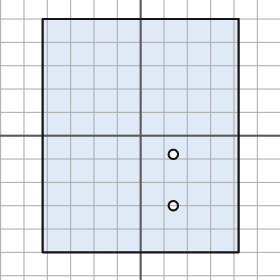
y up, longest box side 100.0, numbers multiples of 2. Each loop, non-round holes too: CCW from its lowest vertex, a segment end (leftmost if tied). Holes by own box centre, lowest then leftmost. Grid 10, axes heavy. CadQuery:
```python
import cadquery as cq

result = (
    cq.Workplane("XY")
    .moveTo(-42.0, -50.0)
    .lineTo(42.0, -50.0)
    .lineTo(42.0, 50.0)
    .lineTo(-42.0, 50.0)
    .close()
    .moveTo(14.0, -30.0)
    .circle(2.0)
    .moveTo(14.0, -8.0)
    .circle(2.0)
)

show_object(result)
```